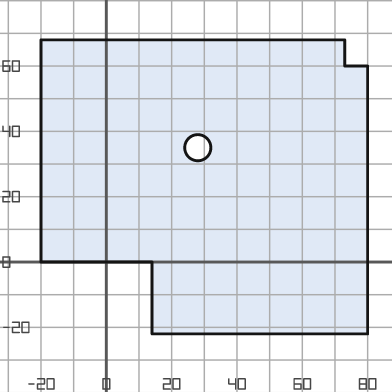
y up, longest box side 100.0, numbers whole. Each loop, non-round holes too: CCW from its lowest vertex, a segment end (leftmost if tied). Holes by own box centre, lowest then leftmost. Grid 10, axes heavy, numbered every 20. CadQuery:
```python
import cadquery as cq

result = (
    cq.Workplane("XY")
    .moveTo(14.0, -22.0)
    .lineTo(80.0, -22.0)
    .lineTo(80.0, 60.0)
    .lineTo(73.0, 60.0)
    .lineTo(73.0, 68.0)
    .lineTo(-20.0, 68.0)
    .lineTo(-20.0, 0.0)
    .lineTo(14.0, 0.0)
    .close()
    .moveTo(28.0, 35.0)
    .circle(4.0)
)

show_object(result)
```